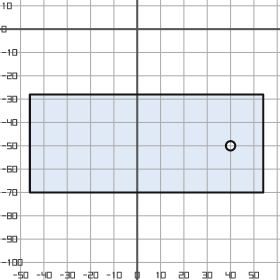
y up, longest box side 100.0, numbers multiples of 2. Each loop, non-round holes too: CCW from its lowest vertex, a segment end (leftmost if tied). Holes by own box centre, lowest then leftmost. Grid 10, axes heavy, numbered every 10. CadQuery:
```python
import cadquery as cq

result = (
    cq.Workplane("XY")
    .moveTo(-46.0, -70.0)
    .lineTo(54.0, -70.0)
    .lineTo(54.0, -28.0)
    .lineTo(-46.0, -28.0)
    .close()
    .moveTo(40.0, -50.0)
    .circle(2.0)
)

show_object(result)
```